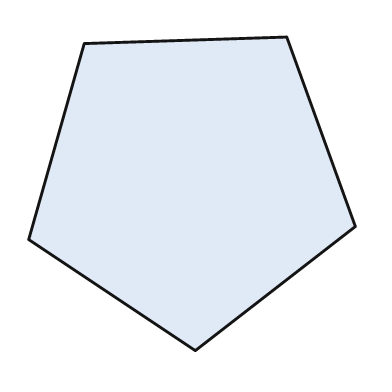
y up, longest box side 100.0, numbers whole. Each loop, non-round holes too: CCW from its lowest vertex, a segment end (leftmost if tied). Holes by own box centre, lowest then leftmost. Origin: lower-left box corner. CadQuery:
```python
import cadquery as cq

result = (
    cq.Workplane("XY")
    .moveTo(51.0, 0.0)
    .lineTo(100.0, 38.0)
    .lineTo(79.0, 96.0)
    .lineTo(17.0, 94.0)
    .lineTo(0.0, 34.0)
    .close()
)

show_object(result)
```